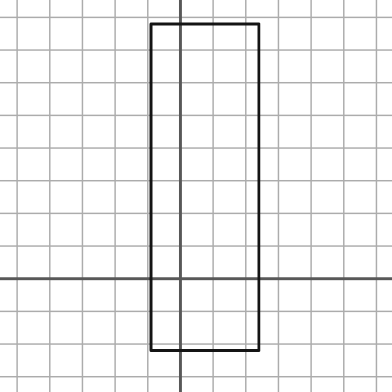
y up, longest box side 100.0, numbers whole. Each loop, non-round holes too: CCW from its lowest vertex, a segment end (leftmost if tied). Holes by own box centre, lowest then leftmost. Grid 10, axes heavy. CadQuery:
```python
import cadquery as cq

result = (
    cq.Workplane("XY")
    .moveTo(-9.0, -22.0)
    .lineTo(24.0, -22.0)
    .lineTo(24.0, 78.0)
    .lineTo(-9.0, 78.0)
    .close()
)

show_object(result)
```